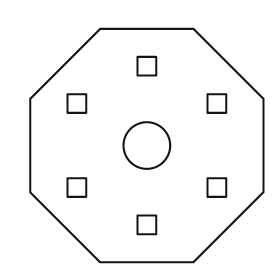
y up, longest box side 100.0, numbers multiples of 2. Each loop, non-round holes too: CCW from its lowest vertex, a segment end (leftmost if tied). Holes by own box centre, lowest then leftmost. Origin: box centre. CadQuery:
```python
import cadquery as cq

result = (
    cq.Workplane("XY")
    .moveTo(-20.0, -50.0)
    .lineTo(20.0, -50.0)
    .lineTo(50.0, -20.0)
    .lineTo(50.0, 20.0)
    .lineTo(20.0, 50.0)
    .lineTo(-20.0, 50.0)
    .lineTo(-50.0, 20.0)
    .lineTo(-50.0, -20.0)
    .close()
    .moveTo(-4.0, -38.0)
    .lineTo(4.0, -38.0)
    .lineTo(4.0, -30.0)
    .lineTo(-4.0, -30.0)
    .close()
    .moveTo(-34.0, -22.0)
    .lineTo(-26.0, -22.0)
    .lineTo(-26.0, -14.0)
    .lineTo(-34.0, -14.0)
    .close()
    .moveTo(26.0, -22.0)
    .lineTo(34.0, -22.0)
    .lineTo(34.0, -14.0)
    .lineTo(26.0, -14.0)
    .close()
    .moveTo(0.0, 0.0)
    .circle(10.0)
    .moveTo(-34.0, 14.0)
    .lineTo(-26.0, 14.0)
    .lineTo(-26.0, 22.0)
    .lineTo(-34.0, 22.0)
    .close()
    .moveTo(26.0, 14.0)
    .lineTo(34.0, 14.0)
    .lineTo(34.0, 22.0)
    .lineTo(26.0, 22.0)
    .close()
    .moveTo(-4.0, 30.0)
    .lineTo(4.0, 30.0)
    .lineTo(4.0, 38.0)
    .lineTo(-4.0, 38.0)
    .close()
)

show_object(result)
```